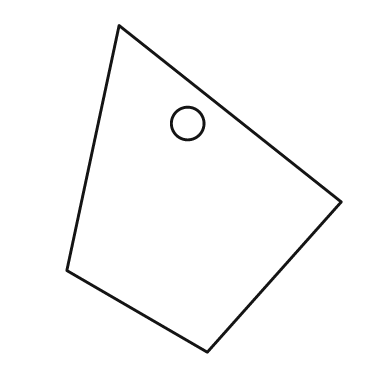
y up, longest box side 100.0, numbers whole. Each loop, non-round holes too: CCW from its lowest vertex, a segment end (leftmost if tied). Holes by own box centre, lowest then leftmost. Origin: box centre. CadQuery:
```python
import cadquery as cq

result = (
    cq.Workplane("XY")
    .moveTo(1.0, -50.0)
    .lineTo(42.0, -4.0)
    .lineTo(-26.0, 50.0)
    .lineTo(-42.0, -25.0)
    .close()
    .moveTo(-5.0, 20.0)
    .circle(5.0)
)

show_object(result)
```